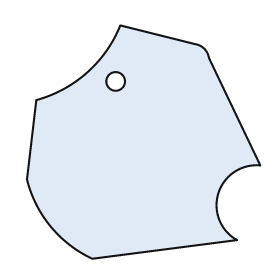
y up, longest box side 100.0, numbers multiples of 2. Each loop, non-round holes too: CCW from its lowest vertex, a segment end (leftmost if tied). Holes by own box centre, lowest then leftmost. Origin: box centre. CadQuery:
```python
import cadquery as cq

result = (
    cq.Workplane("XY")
    .moveTo(-22.0, -50.0)
    .lineTo(40.0, -42.0)
    .threePointArc((32.0, -22.0), (50.0, -10.0))
    .lineTo(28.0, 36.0)
    .threePointArc((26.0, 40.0), (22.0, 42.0))
    .lineTo(-10.0, 50.0)
    .threePointArc((-24.0, 30.0), (-46.0, 18.0))
    .lineTo(-50.0, -16.0)
    .threePointArc((-40.0, -36.0), (-22.0, -50.0))
    .close()
    .moveTo(-12.0, 26.0)
    .circle(4.0)
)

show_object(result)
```